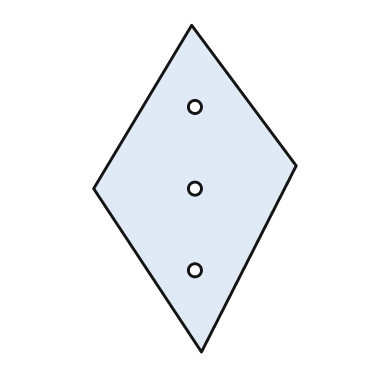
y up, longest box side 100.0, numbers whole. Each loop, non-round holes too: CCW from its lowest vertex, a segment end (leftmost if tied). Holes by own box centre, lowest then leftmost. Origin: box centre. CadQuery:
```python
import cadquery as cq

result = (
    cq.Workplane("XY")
    .moveTo(2.0, -50.0)
    .lineTo(31.0, 7.0)
    .lineTo(-1.0, 50.0)
    .lineTo(-31.0, 0.0)
    .close()
    .moveTo(0.0, -25.0)
    .circle(2.0)
    .moveTo(0.0, 0.0)
    .circle(2.0)
    .moveTo(0.0, 25.0)
    .circle(2.0)
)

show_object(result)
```